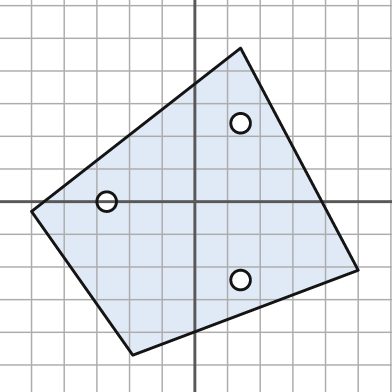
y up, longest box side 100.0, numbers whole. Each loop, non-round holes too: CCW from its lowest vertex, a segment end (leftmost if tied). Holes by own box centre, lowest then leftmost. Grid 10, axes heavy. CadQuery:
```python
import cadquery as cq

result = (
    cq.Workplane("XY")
    .moveTo(-19.0, -47.0)
    .lineTo(50.0, -21.0)
    .lineTo(14.0, 47.0)
    .lineTo(-50.0, -3.0)
    .close()
    .moveTo(14.0, -24.0)
    .circle(3.0)
    .moveTo(-27.0, 0.0)
    .circle(3.0)
    .moveTo(14.0, 24.0)
    .circle(3.0)
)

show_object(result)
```